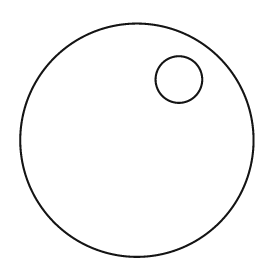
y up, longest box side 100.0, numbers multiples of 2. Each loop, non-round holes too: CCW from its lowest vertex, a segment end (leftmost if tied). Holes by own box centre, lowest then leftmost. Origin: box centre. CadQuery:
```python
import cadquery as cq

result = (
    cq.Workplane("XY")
    .moveTo(0.0, 0.0)
    .circle(50.0)
    .moveTo(18.0, 26.0)
    .circle(10.0)
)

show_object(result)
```